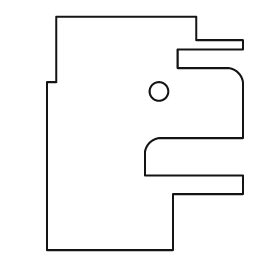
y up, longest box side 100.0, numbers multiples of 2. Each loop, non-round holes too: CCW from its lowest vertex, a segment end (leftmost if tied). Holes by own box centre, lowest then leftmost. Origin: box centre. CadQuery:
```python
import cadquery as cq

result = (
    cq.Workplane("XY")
    .moveTo(-42.0, -50.0)
    .lineTo(12.0, -50.0)
    .lineTo(12.0, -26.0)
    .lineTo(42.0, -26.0)
    .lineTo(42.0, -18.0)
    .lineTo(0.0, -18.0)
    .lineTo(0.0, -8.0)
    .threePointArc((2.0, -4.0), (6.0, -2.0))
    .lineTo(42.0, -2.0)
    .lineTo(42.0, 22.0)
    .threePointArc((40.0, 26.0), (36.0, 28.0))
    .lineTo(14.0, 28.0)
    .lineTo(14.0, 36.0)
    .lineTo(42.0, 36.0)
    .lineTo(42.0, 40.0)
    .lineTo(22.0, 40.0)
    .lineTo(22.0, 50.0)
    .lineTo(-38.0, 50.0)
    .lineTo(-38.0, 22.0)
    .lineTo(-42.0, 22.0)
    .close()
    .moveTo(6.0, 18.0)
    .circle(4.0)
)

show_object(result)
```